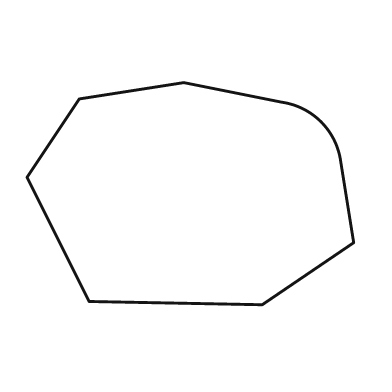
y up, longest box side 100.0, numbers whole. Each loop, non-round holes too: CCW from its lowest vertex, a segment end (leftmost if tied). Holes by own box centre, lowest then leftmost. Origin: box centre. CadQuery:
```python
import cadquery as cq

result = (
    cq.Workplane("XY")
    .moveTo(22.0, -34.0)
    .lineTo(50.0, -15.0)
    .lineTo(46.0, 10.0)
    .threePointArc((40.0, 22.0), (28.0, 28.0))
    .lineTo(-2.0, 34.0)
    .lineTo(-34.0, 29.0)
    .lineTo(-50.0, 5.0)
    .lineTo(-31.0, -33.0)
    .close()
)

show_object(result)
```